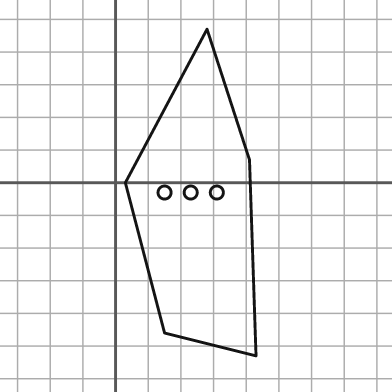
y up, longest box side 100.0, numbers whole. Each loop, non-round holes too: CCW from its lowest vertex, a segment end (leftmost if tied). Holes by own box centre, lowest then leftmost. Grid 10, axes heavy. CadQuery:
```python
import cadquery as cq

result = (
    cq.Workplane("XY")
    .moveTo(43.0, -53.0)
    .lineTo(41.0, 7.0)
    .lineTo(28.0, 47.0)
    .lineTo(3.0, 0.0)
    .lineTo(15.0, -46.0)
    .close()
    .moveTo(15.0, -3.0)
    .circle(2.0)
    .moveTo(23.0, -3.0)
    .circle(2.0)
    .moveTo(31.0, -3.0)
    .circle(2.0)
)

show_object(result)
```